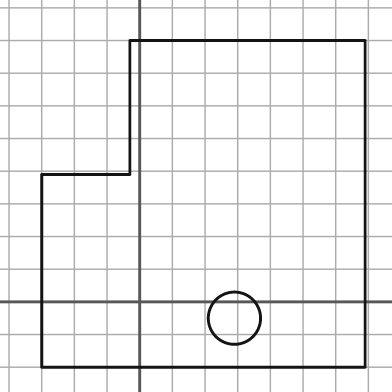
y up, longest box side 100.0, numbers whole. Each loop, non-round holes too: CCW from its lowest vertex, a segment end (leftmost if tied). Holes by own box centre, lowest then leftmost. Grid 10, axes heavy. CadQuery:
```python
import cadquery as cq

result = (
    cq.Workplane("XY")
    .moveTo(-30.0, -20.0)
    .lineTo(69.0, -20.0)
    .lineTo(69.0, 80.0)
    .lineTo(-3.0, 80.0)
    .lineTo(-3.0, 39.0)
    .lineTo(-30.0, 39.0)
    .close()
    .moveTo(29.0, -5.0)
    .circle(8.0)
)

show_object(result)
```